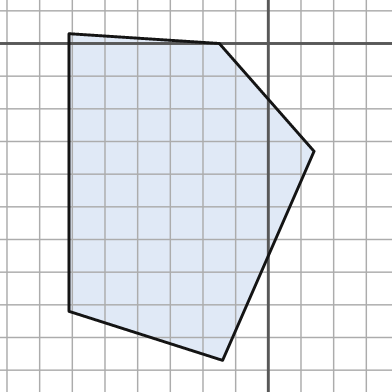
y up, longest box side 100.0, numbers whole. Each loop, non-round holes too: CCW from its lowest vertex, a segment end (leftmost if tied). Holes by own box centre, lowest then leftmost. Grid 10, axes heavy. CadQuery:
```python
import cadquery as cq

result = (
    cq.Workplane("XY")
    .moveTo(-14.0, -97.0)
    .lineTo(14.0, -33.0)
    .lineTo(-15.0, 0.0)
    .lineTo(-61.0, 3.0)
    .lineTo(-61.0, -82.0)
    .close()
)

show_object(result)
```